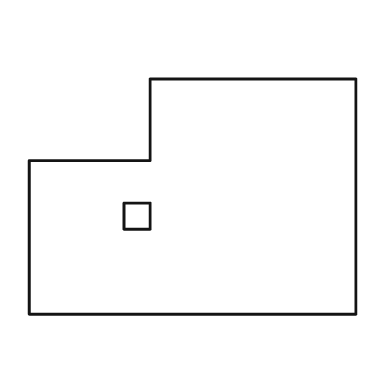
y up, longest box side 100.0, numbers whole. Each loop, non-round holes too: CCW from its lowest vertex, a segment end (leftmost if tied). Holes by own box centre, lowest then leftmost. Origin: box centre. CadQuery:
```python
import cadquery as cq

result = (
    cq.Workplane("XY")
    .moveTo(-50.0, -36.0)
    .lineTo(50.0, -36.0)
    .lineTo(50.0, 36.0)
    .lineTo(-13.0, 36.0)
    .lineTo(-13.0, 11.0)
    .lineTo(-50.0, 11.0)
    .close()
    .moveTo(-21.0, -10.0)
    .lineTo(-13.0, -10.0)
    .lineTo(-13.0, -2.0)
    .lineTo(-21.0, -2.0)
    .close()
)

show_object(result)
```